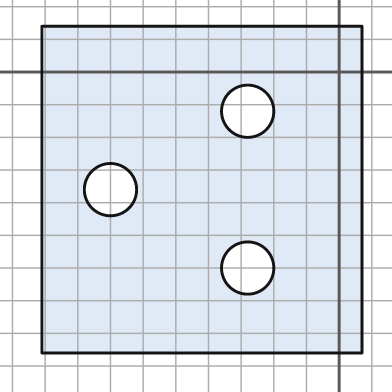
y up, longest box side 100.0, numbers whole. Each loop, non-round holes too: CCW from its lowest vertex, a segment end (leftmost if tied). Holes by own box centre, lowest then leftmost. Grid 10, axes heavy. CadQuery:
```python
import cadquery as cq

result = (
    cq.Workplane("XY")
    .moveTo(-91.0, -86.0)
    .lineTo(7.0, -86.0)
    .lineTo(7.0, 14.0)
    .lineTo(-91.0, 14.0)
    .close()
    .moveTo(-28.0, -60.0)
    .circle(8.0)
    .moveTo(-70.0, -36.0)
    .circle(8.0)
    .moveTo(-28.0, -12.0)
    .circle(8.0)
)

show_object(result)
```